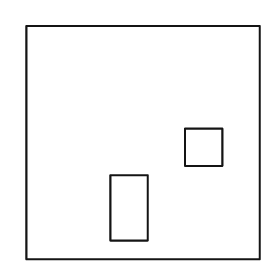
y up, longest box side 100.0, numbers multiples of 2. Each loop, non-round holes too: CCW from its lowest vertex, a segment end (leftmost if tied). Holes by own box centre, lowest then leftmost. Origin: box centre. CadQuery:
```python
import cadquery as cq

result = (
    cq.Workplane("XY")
    .moveTo(-50.0, -50.0)
    .lineTo(50.0, -50.0)
    .lineTo(50.0, 50.0)
    .lineTo(-50.0, 50.0)
    .close()
    .moveTo(-14.0, -42.0)
    .lineTo(2.0, -42.0)
    .lineTo(2.0, -14.0)
    .lineTo(-14.0, -14.0)
    .close()
    .moveTo(18.0, -10.0)
    .lineTo(34.0, -10.0)
    .lineTo(34.0, 6.0)
    .lineTo(18.0, 6.0)
    .close()
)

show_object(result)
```